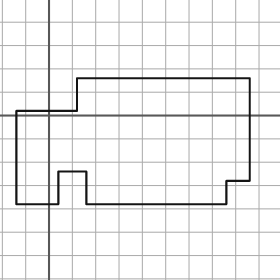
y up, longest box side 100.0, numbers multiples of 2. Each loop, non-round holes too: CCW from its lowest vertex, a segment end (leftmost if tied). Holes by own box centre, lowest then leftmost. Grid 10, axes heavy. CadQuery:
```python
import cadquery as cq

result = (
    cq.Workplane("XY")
    .moveTo(-14.0, -38.0)
    .lineTo(4.0, -38.0)
    .lineTo(4.0, -24.0)
    .lineTo(16.0, -24.0)
    .lineTo(16.0, -38.0)
    .lineTo(76.0, -38.0)
    .lineTo(76.0, -28.0)
    .lineTo(86.0, -28.0)
    .lineTo(86.0, 16.0)
    .lineTo(12.0, 16.0)
    .lineTo(12.0, 2.0)
    .lineTo(-14.0, 2.0)
    .close()
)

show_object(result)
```